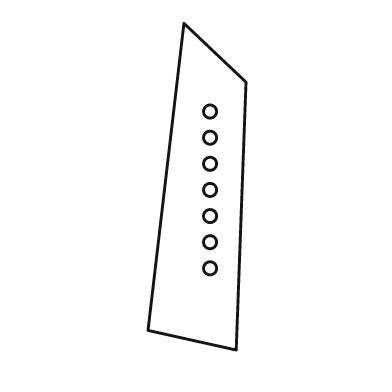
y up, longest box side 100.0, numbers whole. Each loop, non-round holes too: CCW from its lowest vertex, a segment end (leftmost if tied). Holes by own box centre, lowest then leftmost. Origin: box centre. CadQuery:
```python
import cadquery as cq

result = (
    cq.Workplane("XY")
    .moveTo(12.0, -50.0)
    .lineTo(15.0, 32.0)
    .lineTo(-4.0, 50.0)
    .lineTo(-15.0, -44.0)
    .close()
    .moveTo(4.0, -25.0)
    .circle(2.0)
    .moveTo(4.0, -17.0)
    .circle(2.0)
    .moveTo(4.0, -9.0)
    .circle(2.0)
    .moveTo(4.0, -1.0)
    .circle(2.0)
    .moveTo(4.0, 7.0)
    .circle(2.0)
    .moveTo(4.0, 15.0)
    .circle(2.0)
    .moveTo(4.0, 23.0)
    .circle(2.0)
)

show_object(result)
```